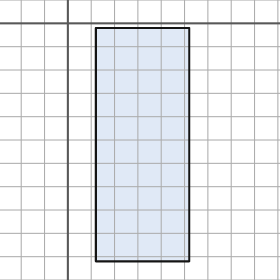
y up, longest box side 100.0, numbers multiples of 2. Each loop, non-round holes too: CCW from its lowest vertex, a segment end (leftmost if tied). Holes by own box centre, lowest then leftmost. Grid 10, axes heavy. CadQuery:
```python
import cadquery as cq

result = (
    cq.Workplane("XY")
    .moveTo(12.0, -102.0)
    .lineTo(52.0, -102.0)
    .lineTo(52.0, -2.0)
    .lineTo(12.0, -2.0)
    .close()
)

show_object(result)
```